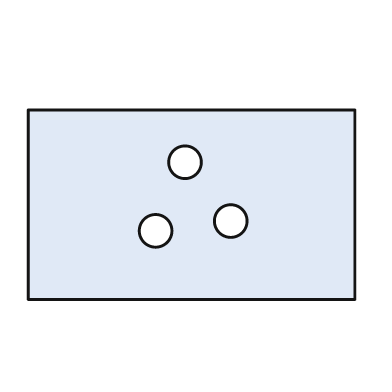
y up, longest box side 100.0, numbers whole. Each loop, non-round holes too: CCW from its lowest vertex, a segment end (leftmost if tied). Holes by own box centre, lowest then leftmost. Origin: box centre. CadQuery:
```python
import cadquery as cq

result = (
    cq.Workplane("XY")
    .moveTo(-50.0, -29.0)
    .lineTo(50.0, -29.0)
    .lineTo(50.0, 29.0)
    .lineTo(-50.0, 29.0)
    .close()
    .moveTo(-11.0, -8.0)
    .circle(5.0)
    .moveTo(12.0, -5.0)
    .circle(5.0)
    .moveTo(-2.0, 13.0)
    .circle(5.0)
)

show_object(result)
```